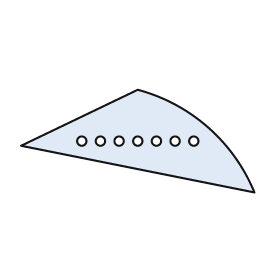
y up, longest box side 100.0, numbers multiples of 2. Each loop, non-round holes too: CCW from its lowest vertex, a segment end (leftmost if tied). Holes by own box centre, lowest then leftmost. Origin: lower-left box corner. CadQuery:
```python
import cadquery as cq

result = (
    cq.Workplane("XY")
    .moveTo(100.0, 0.0)
    .threePointArc((80.0, 28.0), (50.0, 44.0))
    .lineTo(0.0, 20.0)
    .close()
    .moveTo(26.0, 22.0)
    .circle(2.0)
    .moveTo(34.0, 22.0)
    .circle(2.0)
    .moveTo(42.0, 22.0)
    .circle(2.0)
    .moveTo(50.0, 22.0)
    .circle(2.0)
    .moveTo(58.0, 22.0)
    .circle(2.0)
    .moveTo(66.0, 22.0)
    .circle(2.0)
    .moveTo(74.0, 22.0)
    .circle(2.0)
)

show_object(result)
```